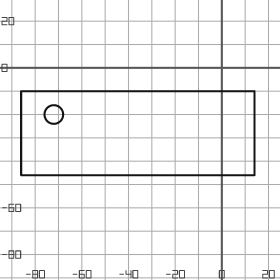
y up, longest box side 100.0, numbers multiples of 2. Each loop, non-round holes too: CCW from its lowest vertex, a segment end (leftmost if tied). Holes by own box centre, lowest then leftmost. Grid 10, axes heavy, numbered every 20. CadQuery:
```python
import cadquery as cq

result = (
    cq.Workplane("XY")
    .moveTo(-86.0, -46.0)
    .lineTo(14.0, -46.0)
    .lineTo(14.0, -10.0)
    .lineTo(-86.0, -10.0)
    .close()
    .moveTo(-72.0, -20.0)
    .circle(4.0)
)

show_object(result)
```